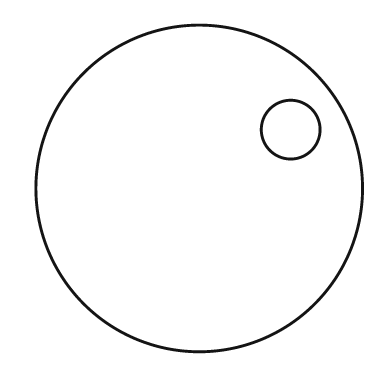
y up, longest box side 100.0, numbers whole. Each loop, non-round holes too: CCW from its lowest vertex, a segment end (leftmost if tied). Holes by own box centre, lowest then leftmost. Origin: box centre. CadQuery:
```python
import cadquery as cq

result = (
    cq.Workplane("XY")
    .moveTo(0.0, 0.0)
    .circle(50.0)
    .moveTo(28.0, 18.0)
    .circle(9.0)
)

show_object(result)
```